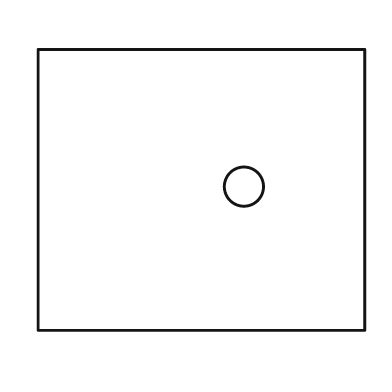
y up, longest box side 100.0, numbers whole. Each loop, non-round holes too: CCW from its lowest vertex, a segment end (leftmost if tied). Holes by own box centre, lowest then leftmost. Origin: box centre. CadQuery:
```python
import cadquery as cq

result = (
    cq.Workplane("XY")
    .moveTo(-50.0, -43.0)
    .lineTo(50.0, -43.0)
    .lineTo(50.0, 43.0)
    .lineTo(-50.0, 43.0)
    .close()
    .moveTo(13.0, 1.0)
    .circle(6.0)
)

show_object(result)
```